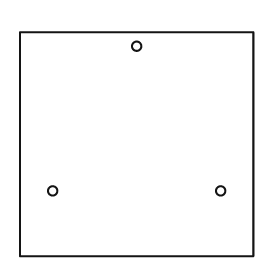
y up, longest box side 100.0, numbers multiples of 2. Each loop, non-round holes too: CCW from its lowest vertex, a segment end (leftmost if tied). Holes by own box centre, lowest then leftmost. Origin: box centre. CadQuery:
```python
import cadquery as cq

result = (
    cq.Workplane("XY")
    .moveTo(-50.0, -48.0)
    .lineTo(50.0, -48.0)
    .lineTo(50.0, 48.0)
    .lineTo(-50.0, 48.0)
    .close()
    .moveTo(-36.0, -20.0)
    .circle(2.0)
    .moveTo(36.0, -20.0)
    .circle(2.0)
    .moveTo(0.0, 42.0)
    .circle(2.0)
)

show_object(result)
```